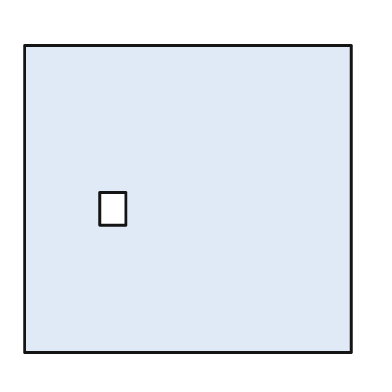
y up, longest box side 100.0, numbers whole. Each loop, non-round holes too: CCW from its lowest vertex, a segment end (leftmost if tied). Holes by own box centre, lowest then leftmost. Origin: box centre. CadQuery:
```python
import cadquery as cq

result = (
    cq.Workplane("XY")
    .moveTo(-50.0, -47.0)
    .lineTo(50.0, -47.0)
    .lineTo(50.0, 47.0)
    .lineTo(-50.0, 47.0)
    .close()
    .moveTo(-27.0, -8.0)
    .lineTo(-19.0, -8.0)
    .lineTo(-19.0, 2.0)
    .lineTo(-27.0, 2.0)
    .close()
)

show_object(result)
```